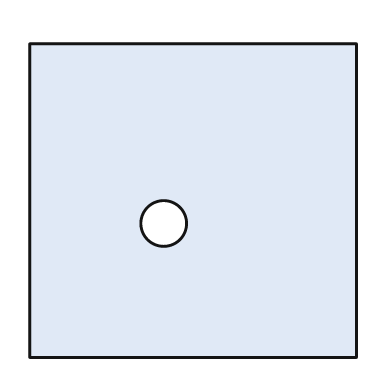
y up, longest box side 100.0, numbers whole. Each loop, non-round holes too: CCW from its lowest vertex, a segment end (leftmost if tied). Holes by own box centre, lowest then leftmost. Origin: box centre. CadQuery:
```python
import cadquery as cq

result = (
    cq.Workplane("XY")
    .moveTo(-50.0, -48.0)
    .lineTo(50.0, -48.0)
    .lineTo(50.0, 48.0)
    .lineTo(-50.0, 48.0)
    .close()
    .moveTo(-9.0, -7.0)
    .circle(7.0)
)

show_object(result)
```